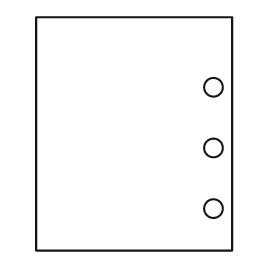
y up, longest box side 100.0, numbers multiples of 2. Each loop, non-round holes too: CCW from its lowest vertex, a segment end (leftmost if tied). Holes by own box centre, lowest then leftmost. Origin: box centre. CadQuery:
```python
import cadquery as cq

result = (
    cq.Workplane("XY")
    .moveTo(-42.0, -50.0)
    .lineTo(42.0, -50.0)
    .lineTo(42.0, 50.0)
    .lineTo(-42.0, 50.0)
    .close()
    .moveTo(34.0, -32.0)
    .circle(4.0)
    .moveTo(34.0, -6.0)
    .circle(4.0)
    .moveTo(34.0, 20.0)
    .circle(4.0)
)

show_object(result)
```